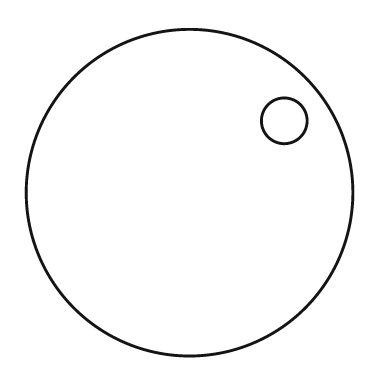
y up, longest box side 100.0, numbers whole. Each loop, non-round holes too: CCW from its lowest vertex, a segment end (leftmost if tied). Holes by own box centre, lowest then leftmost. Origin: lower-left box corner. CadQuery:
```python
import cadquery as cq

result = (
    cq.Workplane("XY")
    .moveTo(50.0, 50.0)
    .circle(50.0)
    .moveTo(79.0, 72.0)
    .circle(7.0)
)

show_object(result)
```